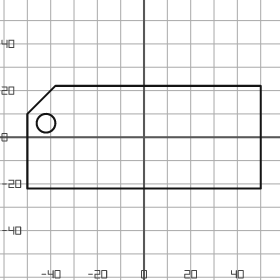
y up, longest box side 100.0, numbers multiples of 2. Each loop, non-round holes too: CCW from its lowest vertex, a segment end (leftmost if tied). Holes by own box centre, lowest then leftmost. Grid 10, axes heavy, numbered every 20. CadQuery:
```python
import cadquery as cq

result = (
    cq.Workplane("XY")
    .moveTo(-50.0, -22.0)
    .lineTo(50.0, -22.0)
    .lineTo(50.0, 22.0)
    .lineTo(-38.0, 22.0)
    .lineTo(-50.0, 10.0)
    .close()
    .moveTo(-42.0, 6.0)
    .circle(4.0)
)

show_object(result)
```